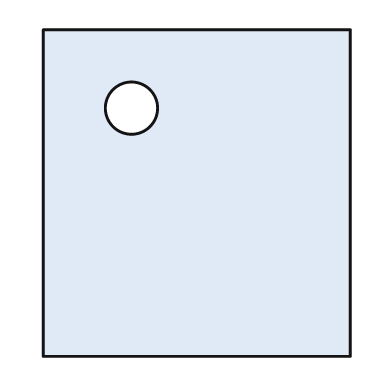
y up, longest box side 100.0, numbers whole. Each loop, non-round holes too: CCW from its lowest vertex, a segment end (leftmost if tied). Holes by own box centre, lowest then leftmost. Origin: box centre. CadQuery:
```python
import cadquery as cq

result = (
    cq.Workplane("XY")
    .moveTo(-47.0, -50.0)
    .lineTo(47.0, -50.0)
    .lineTo(47.0, 50.0)
    .lineTo(-47.0, 50.0)
    .close()
    .moveTo(-20.0, 26.0)
    .circle(8.0)
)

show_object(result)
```